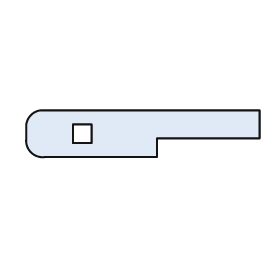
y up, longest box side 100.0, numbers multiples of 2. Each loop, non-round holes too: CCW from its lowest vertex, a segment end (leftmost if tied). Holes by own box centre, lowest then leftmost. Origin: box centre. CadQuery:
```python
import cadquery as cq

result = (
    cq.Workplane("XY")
    .moveTo(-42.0, -10.0)
    .lineTo(6.0, -10.0)
    .lineTo(6.0, -2.0)
    .lineTo(50.0, -2.0)
    .lineTo(50.0, 10.0)
    .lineTo(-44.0, 10.0)
    .threePointArc((-48.0, 8.0), (-50.0, 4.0))
    .lineTo(-50.0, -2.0)
    .threePointArc((-48.0, -8.0), (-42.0, -10.0))
    .close()
    .moveTo(-30.0, -4.0)
    .lineTo(-22.0, -4.0)
    .lineTo(-22.0, 4.0)
    .lineTo(-30.0, 4.0)
    .close()
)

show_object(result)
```